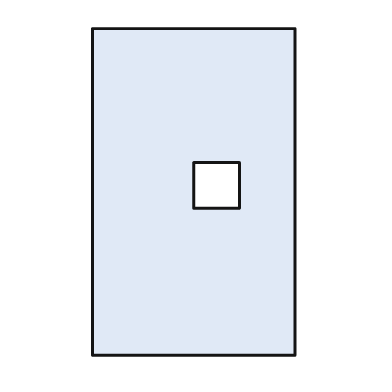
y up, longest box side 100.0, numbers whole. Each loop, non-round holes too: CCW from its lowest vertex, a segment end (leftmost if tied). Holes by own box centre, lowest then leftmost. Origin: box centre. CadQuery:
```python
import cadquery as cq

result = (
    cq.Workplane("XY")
    .moveTo(-31.0, -50.0)
    .lineTo(31.0, -50.0)
    .lineTo(31.0, 50.0)
    .lineTo(-31.0, 50.0)
    .close()
    .moveTo(0.0, -5.0)
    .lineTo(14.0, -5.0)
    .lineTo(14.0, 9.0)
    .lineTo(0.0, 9.0)
    .close()
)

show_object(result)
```